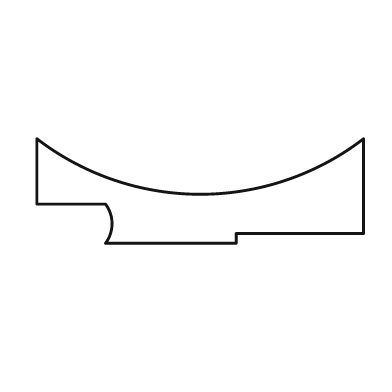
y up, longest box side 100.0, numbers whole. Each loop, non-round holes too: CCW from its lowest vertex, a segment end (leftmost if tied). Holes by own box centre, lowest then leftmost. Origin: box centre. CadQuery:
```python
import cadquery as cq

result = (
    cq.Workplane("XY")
    .moveTo(-29.0, -16.0)
    .lineTo(11.0, -16.0)
    .lineTo(11.0, -13.0)
    .lineTo(50.0, -13.0)
    .lineTo(50.0, 16.0)
    .threePointArc((0.0, -1.0), (-50.0, 16.0))
    .lineTo(-50.0, -4.0)
    .lineTo(-29.0, -4.0)
    .threePointArc((-27.0, -10.0), (-29.0, -16.0))
    .close()
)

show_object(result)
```